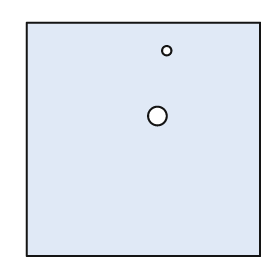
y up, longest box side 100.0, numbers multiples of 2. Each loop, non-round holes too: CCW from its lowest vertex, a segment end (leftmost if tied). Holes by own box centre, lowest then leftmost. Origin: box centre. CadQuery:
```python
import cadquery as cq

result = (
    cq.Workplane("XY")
    .moveTo(-50.0, -50.0)
    .lineTo(50.0, -50.0)
    .lineTo(50.0, 50.0)
    .lineTo(-50.0, 50.0)
    .close()
    .moveTo(6.0, 10.0)
    .circle(4.0)
    .moveTo(10.0, 38.0)
    .circle(2.0)
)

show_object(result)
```